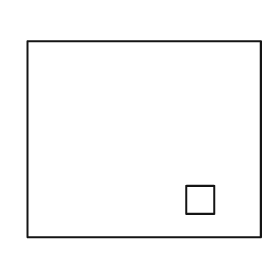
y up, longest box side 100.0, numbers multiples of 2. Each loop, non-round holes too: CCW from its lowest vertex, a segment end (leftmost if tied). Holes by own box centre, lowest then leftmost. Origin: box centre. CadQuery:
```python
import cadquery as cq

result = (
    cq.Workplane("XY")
    .moveTo(-50.0, -42.0)
    .lineTo(50.0, -42.0)
    .lineTo(50.0, 42.0)
    .lineTo(-50.0, 42.0)
    .close()
    .moveTo(18.0, -32.0)
    .lineTo(30.0, -32.0)
    .lineTo(30.0, -20.0)
    .lineTo(18.0, -20.0)
    .close()
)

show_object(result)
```